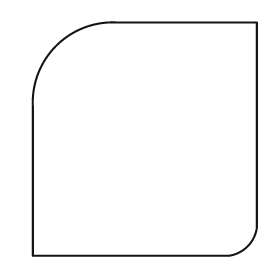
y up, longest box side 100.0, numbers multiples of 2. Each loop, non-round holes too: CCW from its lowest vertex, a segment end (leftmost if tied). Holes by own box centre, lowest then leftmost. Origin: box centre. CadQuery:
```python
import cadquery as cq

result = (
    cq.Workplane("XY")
    .moveTo(-48.0, -50.0)
    .lineTo(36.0, -50.0)
    .threePointArc((44.0, -46.0), (48.0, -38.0))
    .lineTo(48.0, 50.0)
    .lineTo(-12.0, 50.0)
    .threePointArc((-38.0, 40.0), (-48.0, 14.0))
    .close()
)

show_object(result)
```